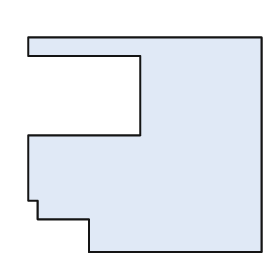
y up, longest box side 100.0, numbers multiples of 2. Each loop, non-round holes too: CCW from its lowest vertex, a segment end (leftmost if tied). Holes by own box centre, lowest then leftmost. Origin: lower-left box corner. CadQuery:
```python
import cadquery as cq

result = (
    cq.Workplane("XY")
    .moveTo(26.0, 0.0)
    .lineTo(100.0, 0.0)
    .lineTo(100.0, 92.0)
    .lineTo(0.0, 92.0)
    .lineTo(0.0, 84.0)
    .lineTo(48.0, 84.0)
    .lineTo(48.0, 50.0)
    .lineTo(0.0, 50.0)
    .lineTo(0.0, 22.0)
    .lineTo(4.0, 22.0)
    .lineTo(4.0, 14.0)
    .lineTo(26.0, 14.0)
    .close()
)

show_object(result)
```